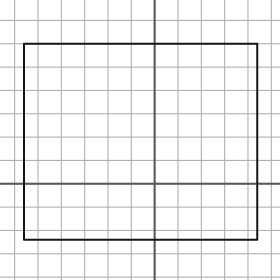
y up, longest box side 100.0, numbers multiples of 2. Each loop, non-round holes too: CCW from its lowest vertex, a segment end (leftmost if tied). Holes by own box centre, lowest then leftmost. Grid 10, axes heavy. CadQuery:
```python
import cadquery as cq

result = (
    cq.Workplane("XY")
    .moveTo(-56.0, -24.0)
    .lineTo(44.0, -24.0)
    .lineTo(44.0, 60.0)
    .lineTo(-56.0, 60.0)
    .close()
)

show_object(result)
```